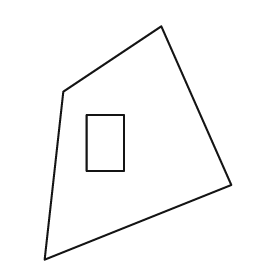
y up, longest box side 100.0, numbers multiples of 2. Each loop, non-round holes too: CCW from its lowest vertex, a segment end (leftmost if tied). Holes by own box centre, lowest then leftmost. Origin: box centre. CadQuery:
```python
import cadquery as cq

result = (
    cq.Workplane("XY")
    .moveTo(-40.0, -50.0)
    .lineTo(40.0, -18.0)
    .lineTo(10.0, 50.0)
    .lineTo(-32.0, 22.0)
    .close()
    .moveTo(-22.0, -12.0)
    .lineTo(-6.0, -12.0)
    .lineTo(-6.0, 12.0)
    .lineTo(-22.0, 12.0)
    .close()
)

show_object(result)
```